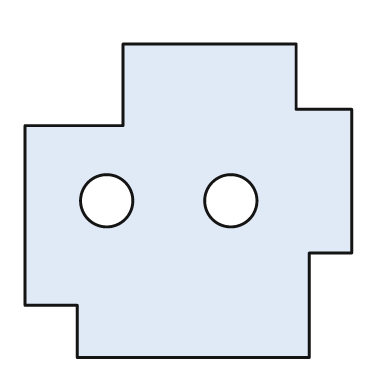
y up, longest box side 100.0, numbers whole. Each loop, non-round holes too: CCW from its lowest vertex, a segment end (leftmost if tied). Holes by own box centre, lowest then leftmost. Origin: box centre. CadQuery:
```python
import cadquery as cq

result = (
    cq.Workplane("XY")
    .moveTo(-34.0, -48.0)
    .lineTo(37.0, -48.0)
    .lineTo(37.0, -16.0)
    .lineTo(50.0, -16.0)
    .lineTo(50.0, 28.0)
    .lineTo(33.0, 28.0)
    .lineTo(33.0, 48.0)
    .lineTo(-20.0, 48.0)
    .lineTo(-20.0, 23.0)
    .lineTo(-50.0, 23.0)
    .lineTo(-50.0, -32.0)
    .lineTo(-34.0, -32.0)
    .close()
    .moveTo(-25.0, 0.0)
    .circle(8.0)
    .moveTo(13.0, 0.0)
    .circle(8.0)
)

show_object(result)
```